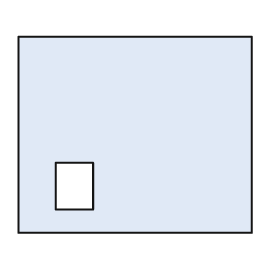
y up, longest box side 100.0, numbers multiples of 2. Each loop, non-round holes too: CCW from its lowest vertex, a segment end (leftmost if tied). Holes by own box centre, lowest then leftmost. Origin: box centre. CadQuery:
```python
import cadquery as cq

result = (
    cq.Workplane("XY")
    .moveTo(-50.0, -42.0)
    .lineTo(50.0, -42.0)
    .lineTo(50.0, 42.0)
    .lineTo(-50.0, 42.0)
    .close()
    .moveTo(-34.0, -32.0)
    .lineTo(-18.0, -32.0)
    .lineTo(-18.0, -12.0)
    .lineTo(-34.0, -12.0)
    .close()
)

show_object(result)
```